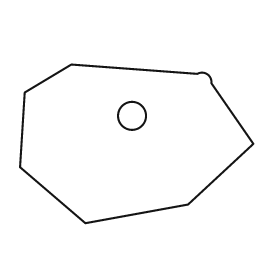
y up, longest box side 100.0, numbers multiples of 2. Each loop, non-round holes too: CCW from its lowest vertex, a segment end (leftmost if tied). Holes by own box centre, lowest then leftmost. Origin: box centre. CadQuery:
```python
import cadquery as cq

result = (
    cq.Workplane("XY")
    .moveTo(-22.0, -34.0)
    .lineTo(22.0, -26.0)
    .lineTo(50.0, 0.0)
    .lineTo(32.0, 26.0)
    .threePointArc((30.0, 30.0), (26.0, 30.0))
    .lineTo(-28.0, 34.0)
    .lineTo(-48.0, 22.0)
    .lineTo(-50.0, -10.0)
    .close()
    .moveTo(-2.0, 12.0)
    .circle(6.0)
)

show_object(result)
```